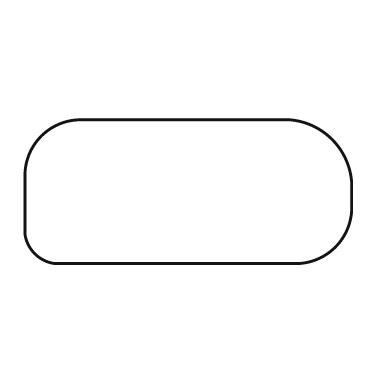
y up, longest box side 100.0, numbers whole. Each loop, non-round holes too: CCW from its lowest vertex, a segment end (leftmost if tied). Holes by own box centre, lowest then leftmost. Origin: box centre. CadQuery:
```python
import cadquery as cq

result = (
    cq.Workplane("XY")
    .moveTo(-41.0, -22.0)
    .lineTo(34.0, -22.0)
    .threePointArc((45.0, -17.0), (50.0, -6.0))
    .lineTo(50.0, 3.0)
    .threePointArc((44.0, 16.0), (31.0, 22.0))
    .lineTo(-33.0, 22.0)
    .threePointArc((-45.0, 17.0), (-50.0, 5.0))
    .lineTo(-50.0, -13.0)
    .threePointArc((-47.0, -19.0), (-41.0, -22.0))
    .close()
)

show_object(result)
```